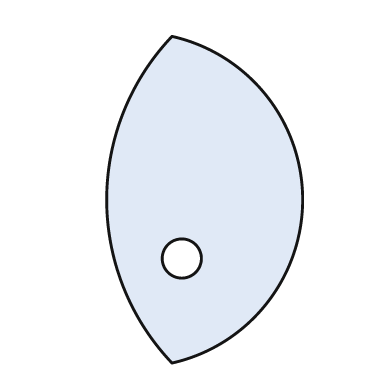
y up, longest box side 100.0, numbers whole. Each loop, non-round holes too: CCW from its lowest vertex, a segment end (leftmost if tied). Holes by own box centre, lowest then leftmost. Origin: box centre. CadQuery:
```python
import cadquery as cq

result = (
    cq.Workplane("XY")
    .moveTo(-10.0, -50.0)
    .threePointArc((30.0, 0.0), (-10.0, 50.0))
    .threePointArc((-30.0, 0.0), (-10.0, -50.0))
    .close()
    .moveTo(-7.0, -18.0)
    .circle(6.0)
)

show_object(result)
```